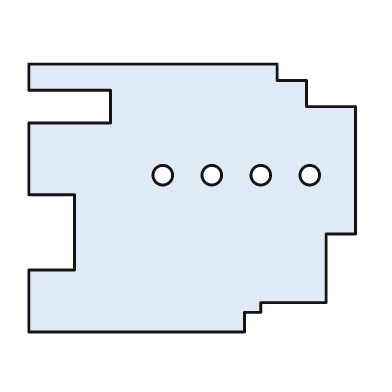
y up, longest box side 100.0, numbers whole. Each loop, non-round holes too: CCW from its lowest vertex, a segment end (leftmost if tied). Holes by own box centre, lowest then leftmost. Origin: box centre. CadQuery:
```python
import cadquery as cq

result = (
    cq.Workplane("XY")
    .moveTo(-50.0, -41.0)
    .lineTo(16.0, -41.0)
    .lineTo(16.0, -35.0)
    .lineTo(21.0, -35.0)
    .lineTo(21.0, -32.0)
    .lineTo(41.0, -32.0)
    .lineTo(41.0, -11.0)
    .lineTo(50.0, -11.0)
    .lineTo(50.0, 28.0)
    .lineTo(35.0, 28.0)
    .lineTo(35.0, 36.0)
    .lineTo(26.0, 36.0)
    .lineTo(26.0, 41.0)
    .lineTo(-50.0, 41.0)
    .lineTo(-50.0, 33.0)
    .lineTo(-25.0, 33.0)
    .lineTo(-25.0, 23.0)
    .lineTo(-50.0, 23.0)
    .lineTo(-50.0, 1.0)
    .lineTo(-36.0, 1.0)
    .lineTo(-36.0, -22.0)
    .lineTo(-50.0, -22.0)
    .close()
    .moveTo(-9.0, 7.0)
    .circle(3.0)
    .moveTo(6.0, 7.0)
    .circle(3.0)
    .moveTo(21.0, 7.0)
    .circle(3.0)
    .moveTo(36.0, 7.0)
    .circle(3.0)
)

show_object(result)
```